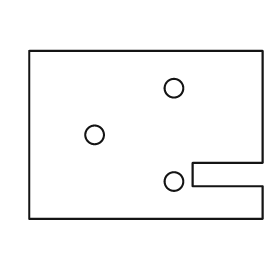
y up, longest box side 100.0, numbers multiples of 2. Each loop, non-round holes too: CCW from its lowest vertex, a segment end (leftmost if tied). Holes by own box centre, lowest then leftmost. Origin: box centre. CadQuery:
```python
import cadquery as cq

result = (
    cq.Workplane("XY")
    .moveTo(-50.0, -36.0)
    .lineTo(50.0, -36.0)
    .lineTo(50.0, -22.0)
    .lineTo(20.0, -22.0)
    .lineTo(20.0, -12.0)
    .lineTo(50.0, -12.0)
    .lineTo(50.0, 36.0)
    .lineTo(-50.0, 36.0)
    .close()
    .moveTo(12.0, -20.0)
    .circle(4.0)
    .moveTo(-22.0, 0.0)
    .circle(4.0)
    .moveTo(12.0, 20.0)
    .circle(4.0)
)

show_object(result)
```